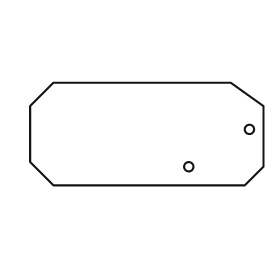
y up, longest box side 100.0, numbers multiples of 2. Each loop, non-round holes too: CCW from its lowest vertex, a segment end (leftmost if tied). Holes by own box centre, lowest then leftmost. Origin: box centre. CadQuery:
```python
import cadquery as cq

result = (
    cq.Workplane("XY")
    .moveTo(-40.0, -22.0)
    .lineTo(42.0, -22.0)
    .lineTo(50.0, -14.0)
    .lineTo(50.0, 12.0)
    .lineTo(36.0, 22.0)
    .lineTo(-40.0, 22.0)
    .lineTo(-50.0, 12.0)
    .lineTo(-50.0, -12.0)
    .close()
    .moveTo(18.0, -14.0)
    .circle(2.0)
    .moveTo(44.0, 2.0)
    .circle(2.0)
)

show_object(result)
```